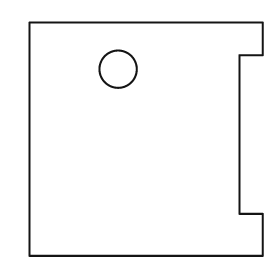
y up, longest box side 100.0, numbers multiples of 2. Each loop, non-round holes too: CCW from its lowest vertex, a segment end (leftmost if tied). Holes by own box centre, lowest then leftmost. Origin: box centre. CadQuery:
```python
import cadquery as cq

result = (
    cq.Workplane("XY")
    .moveTo(-50.0, -50.0)
    .lineTo(50.0, -50.0)
    .lineTo(50.0, -32.0)
    .lineTo(40.0, -32.0)
    .lineTo(40.0, 36.0)
    .lineTo(50.0, 36.0)
    .lineTo(50.0, 50.0)
    .lineTo(-50.0, 50.0)
    .close()
    .moveTo(-12.0, 30.0)
    .circle(8.0)
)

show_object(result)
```